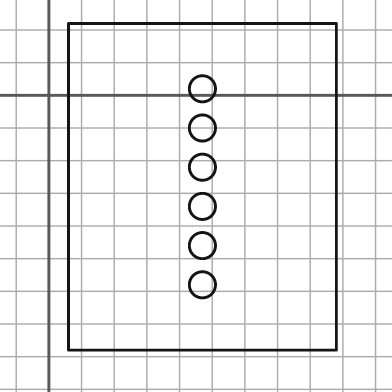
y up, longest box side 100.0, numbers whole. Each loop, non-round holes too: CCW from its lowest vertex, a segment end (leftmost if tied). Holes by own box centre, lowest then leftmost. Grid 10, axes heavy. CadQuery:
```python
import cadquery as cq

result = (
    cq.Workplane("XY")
    .moveTo(6.0, -78.0)
    .lineTo(88.0, -78.0)
    .lineTo(88.0, 22.0)
    .lineTo(6.0, 22.0)
    .close()
    .moveTo(47.0, -58.0)
    .circle(4.0)
    .moveTo(47.0, -46.0)
    .circle(4.0)
    .moveTo(47.0, -34.0)
    .circle(4.0)
    .moveTo(47.0, -22.0)
    .circle(4.0)
    .moveTo(47.0, -10.0)
    .circle(4.0)
    .moveTo(47.0, 2.0)
    .circle(4.0)
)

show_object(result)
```